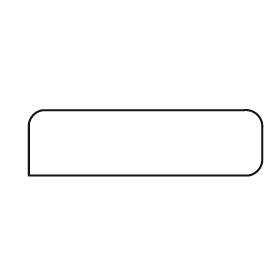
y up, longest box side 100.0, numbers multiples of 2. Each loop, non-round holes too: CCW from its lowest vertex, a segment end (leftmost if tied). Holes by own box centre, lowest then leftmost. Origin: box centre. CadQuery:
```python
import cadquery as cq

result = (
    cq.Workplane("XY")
    .moveTo(-50.0, -14.0)
    .lineTo(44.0, -14.0)
    .threePointArc((48.0, -12.0), (50.0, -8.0))
    .lineTo(50.0, 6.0)
    .threePointArc((48.0, 12.0), (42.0, 14.0))
    .lineTo(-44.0, 14.0)
    .threePointArc((-48.0, 12.0), (-50.0, 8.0))
    .close()
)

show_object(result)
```